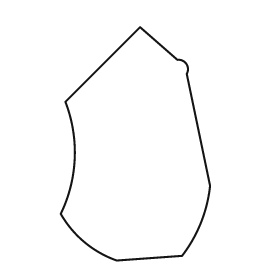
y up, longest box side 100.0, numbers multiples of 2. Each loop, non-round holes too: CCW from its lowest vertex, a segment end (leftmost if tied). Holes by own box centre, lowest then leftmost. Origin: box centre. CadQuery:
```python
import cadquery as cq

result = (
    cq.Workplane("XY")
    .moveTo(-8.0, -50.0)
    .lineTo(20.0, -48.0)
    .threePointArc((28.0, -34.0), (32.0, -18.0))
    .lineTo(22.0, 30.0)
    .threePointArc((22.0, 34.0), (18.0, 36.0))
    .lineTo(2.0, 50.0)
    .lineTo(-30.0, 18.0)
    .threePointArc((-26.0, -6.0), (-32.0, -30.0))
    .threePointArc((-22.0, -42.0), (-8.0, -50.0))
    .close()
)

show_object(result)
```